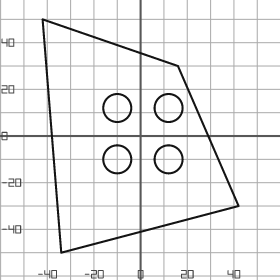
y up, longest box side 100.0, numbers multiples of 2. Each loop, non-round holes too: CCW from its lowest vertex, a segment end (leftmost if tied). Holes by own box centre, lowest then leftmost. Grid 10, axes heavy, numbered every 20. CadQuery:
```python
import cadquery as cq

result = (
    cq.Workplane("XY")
    .moveTo(-34.0, -50.0)
    .lineTo(42.0, -30.0)
    .lineTo(16.0, 30.0)
    .lineTo(-42.0, 50.0)
    .close()
    .moveTo(-10.0, -10.0)
    .circle(6.0)
    .moveTo(12.0, -10.0)
    .circle(6.0)
    .moveTo(-10.0, 12.0)
    .circle(6.0)
    .moveTo(12.0, 12.0)
    .circle(6.0)
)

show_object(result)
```